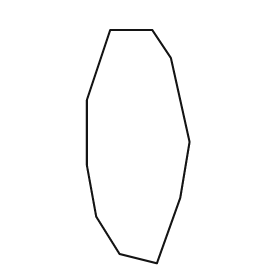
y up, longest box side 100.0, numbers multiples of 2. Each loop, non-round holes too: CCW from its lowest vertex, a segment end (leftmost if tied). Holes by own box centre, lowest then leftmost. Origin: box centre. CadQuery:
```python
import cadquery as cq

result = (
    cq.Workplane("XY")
    .moveTo(8.0, -50.0)
    .lineTo(18.0, -22.0)
    .lineTo(22.0, 2.0)
    .lineTo(14.0, 38.0)
    .lineTo(6.0, 50.0)
    .lineTo(-12.0, 50.0)
    .lineTo(-22.0, 20.0)
    .lineTo(-22.0, -8.0)
    .lineTo(-18.0, -30.0)
    .lineTo(-8.0, -46.0)
    .close()
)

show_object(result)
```